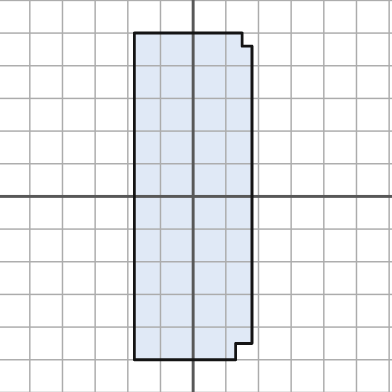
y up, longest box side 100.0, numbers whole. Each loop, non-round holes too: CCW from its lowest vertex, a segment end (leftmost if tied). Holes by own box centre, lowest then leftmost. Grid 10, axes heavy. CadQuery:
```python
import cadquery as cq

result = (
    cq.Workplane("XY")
    .moveTo(-18.0, -50.0)
    .lineTo(13.0, -50.0)
    .lineTo(13.0, -45.0)
    .lineTo(18.0, -45.0)
    .lineTo(18.0, 46.0)
    .lineTo(15.0, 46.0)
    .lineTo(15.0, 50.0)
    .lineTo(-18.0, 50.0)
    .close()
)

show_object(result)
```